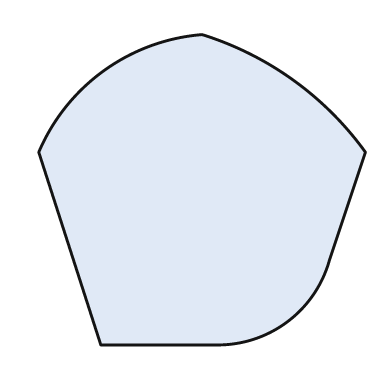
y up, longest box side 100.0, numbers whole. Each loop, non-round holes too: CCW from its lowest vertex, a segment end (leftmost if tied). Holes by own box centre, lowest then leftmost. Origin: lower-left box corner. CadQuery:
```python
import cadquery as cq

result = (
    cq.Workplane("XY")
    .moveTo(19.0, 0.0)
    .lineTo(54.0, 0.0)
    .threePointArc((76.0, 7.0), (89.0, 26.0))
    .lineTo(100.0, 59.0)
    .threePointArc((78.0, 81.0), (50.0, 95.0))
    .threePointArc((20.0, 84.0), (0.0, 59.0))
    .close()
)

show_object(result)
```